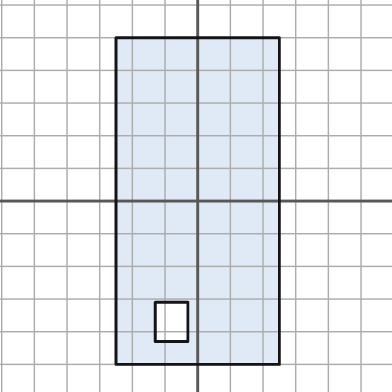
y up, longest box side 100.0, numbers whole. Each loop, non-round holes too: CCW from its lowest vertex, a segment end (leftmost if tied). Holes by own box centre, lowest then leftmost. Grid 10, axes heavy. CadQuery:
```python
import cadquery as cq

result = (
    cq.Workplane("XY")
    .moveTo(-25.0, -50.0)
    .lineTo(25.0, -50.0)
    .lineTo(25.0, 50.0)
    .lineTo(-25.0, 50.0)
    .close()
    .moveTo(-13.0, -43.0)
    .lineTo(-3.0, -43.0)
    .lineTo(-3.0, -31.0)
    .lineTo(-13.0, -31.0)
    .close()
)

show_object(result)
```